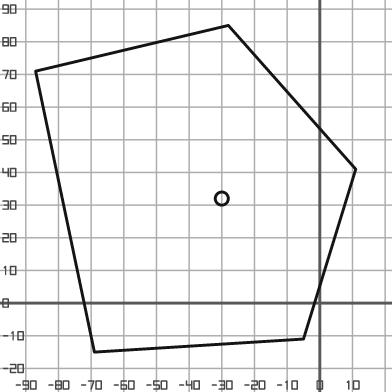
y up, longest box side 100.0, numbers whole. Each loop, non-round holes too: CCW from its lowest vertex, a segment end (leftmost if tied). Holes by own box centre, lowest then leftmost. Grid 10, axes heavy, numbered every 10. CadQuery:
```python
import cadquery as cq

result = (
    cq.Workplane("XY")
    .moveTo(-69.0, -15.0)
    .lineTo(-5.0, -11.0)
    .lineTo(11.0, 41.0)
    .lineTo(-28.0, 85.0)
    .lineTo(-87.0, 71.0)
    .close()
    .moveTo(-30.0, 32.0)
    .circle(2.0)
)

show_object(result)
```